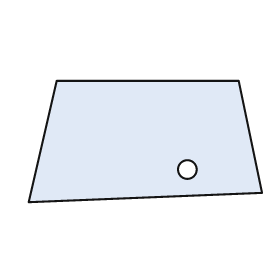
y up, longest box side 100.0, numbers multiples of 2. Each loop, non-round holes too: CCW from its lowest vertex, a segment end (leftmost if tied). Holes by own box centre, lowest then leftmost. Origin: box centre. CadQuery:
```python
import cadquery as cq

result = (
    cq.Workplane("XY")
    .moveTo(-50.0, -26.0)
    .lineTo(50.0, -22.0)
    .lineTo(40.0, 26.0)
    .lineTo(-38.0, 26.0)
    .close()
    .moveTo(18.0, -12.0)
    .circle(4.0)
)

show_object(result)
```